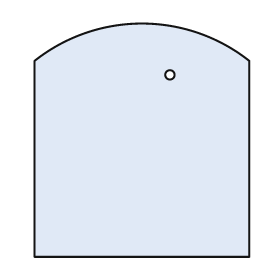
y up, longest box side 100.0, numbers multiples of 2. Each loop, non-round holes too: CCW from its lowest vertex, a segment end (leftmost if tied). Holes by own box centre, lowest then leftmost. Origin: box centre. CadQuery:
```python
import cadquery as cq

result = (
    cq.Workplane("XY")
    .moveTo(-46.0, -50.0)
    .lineTo(46.0, -50.0)
    .lineTo(46.0, 34.0)
    .threePointArc((0.0, 50.0), (-46.0, 34.0))
    .close()
    .moveTo(12.0, 28.0)
    .circle(2.0)
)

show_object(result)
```